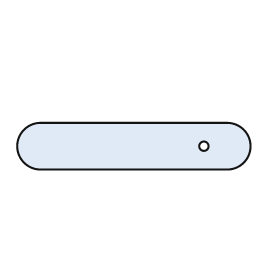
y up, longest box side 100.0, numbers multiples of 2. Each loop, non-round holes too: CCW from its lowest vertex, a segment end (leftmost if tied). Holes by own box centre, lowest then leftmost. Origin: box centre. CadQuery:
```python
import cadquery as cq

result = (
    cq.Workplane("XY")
    .moveTo(-40.0, -10.0)
    .lineTo(40.0, -10.0)
    .threePointArc((50.0, 0.0), (40.0, 10.0))
    .lineTo(-40.0, 10.0)
    .threePointArc((-50.0, 0.0), (-40.0, -10.0))
    .close()
    .moveTo(30.0, 0.0)
    .circle(2.0)
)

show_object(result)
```